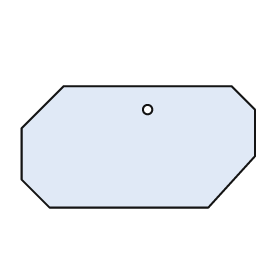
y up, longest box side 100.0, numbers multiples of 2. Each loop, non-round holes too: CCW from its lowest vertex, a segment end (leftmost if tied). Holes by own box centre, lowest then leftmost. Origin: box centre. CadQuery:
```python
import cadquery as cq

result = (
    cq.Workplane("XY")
    .moveTo(-38.0, -26.0)
    .lineTo(30.0, -26.0)
    .lineTo(50.0, -4.0)
    .lineTo(50.0, 16.0)
    .lineTo(40.0, 26.0)
    .lineTo(-32.0, 26.0)
    .lineTo(-50.0, 8.0)
    .lineTo(-50.0, -14.0)
    .close()
    .moveTo(4.0, 16.0)
    .circle(2.0)
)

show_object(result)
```